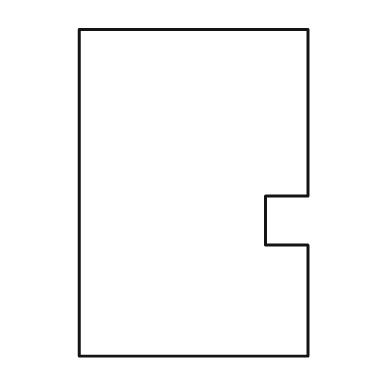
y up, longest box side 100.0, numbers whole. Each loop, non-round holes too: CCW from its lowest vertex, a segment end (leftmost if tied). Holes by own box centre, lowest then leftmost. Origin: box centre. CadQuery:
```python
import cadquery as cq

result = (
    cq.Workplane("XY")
    .moveTo(-35.0, -50.0)
    .lineTo(35.0, -50.0)
    .lineTo(35.0, -16.0)
    .lineTo(22.0, -16.0)
    .lineTo(22.0, -1.0)
    .lineTo(35.0, -1.0)
    .lineTo(35.0, 50.0)
    .lineTo(-35.0, 50.0)
    .close()
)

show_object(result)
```